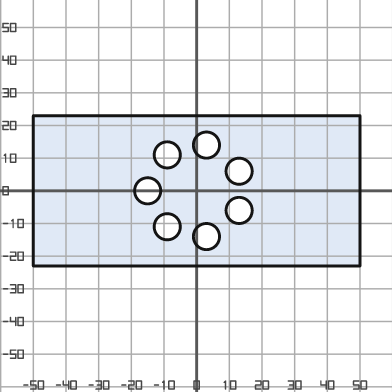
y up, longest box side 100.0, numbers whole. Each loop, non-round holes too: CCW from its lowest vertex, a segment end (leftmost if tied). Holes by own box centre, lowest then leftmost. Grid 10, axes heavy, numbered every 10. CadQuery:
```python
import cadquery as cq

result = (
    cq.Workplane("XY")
    .moveTo(-50.0, -23.0)
    .lineTo(50.0, -23.0)
    .lineTo(50.0, 23.0)
    .lineTo(-50.0, 23.0)
    .close()
    .moveTo(3.0, -14.0)
    .circle(4.0)
    .moveTo(-9.0, -11.0)
    .circle(4.0)
    .moveTo(13.0, -6.0)
    .circle(4.0)
    .moveTo(-15.0, 0.0)
    .circle(4.0)
    .moveTo(13.0, 6.0)
    .circle(4.0)
    .moveTo(-9.0, 11.0)
    .circle(4.0)
    .moveTo(3.0, 14.0)
    .circle(4.0)
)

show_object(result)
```